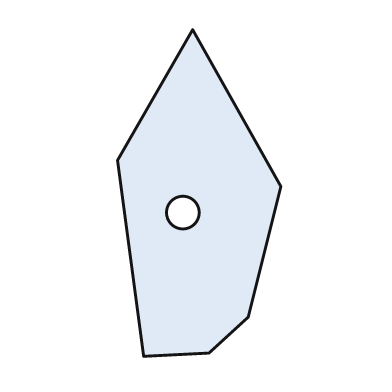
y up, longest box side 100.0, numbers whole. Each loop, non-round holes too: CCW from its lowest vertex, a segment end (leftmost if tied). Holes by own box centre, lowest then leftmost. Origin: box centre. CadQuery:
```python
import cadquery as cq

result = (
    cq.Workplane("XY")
    .moveTo(-17.0, -50.0)
    .lineTo(3.0, -49.0)
    .lineTo(15.0, -38.0)
    .lineTo(25.0, 2.0)
    .lineTo(-2.0, 50.0)
    .lineTo(-25.0, 10.0)
    .close()
    .moveTo(-5.0, -6.0)
    .circle(5.0)
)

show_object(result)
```